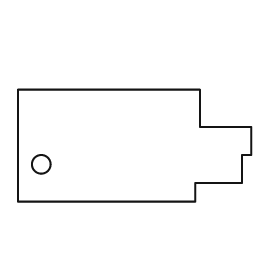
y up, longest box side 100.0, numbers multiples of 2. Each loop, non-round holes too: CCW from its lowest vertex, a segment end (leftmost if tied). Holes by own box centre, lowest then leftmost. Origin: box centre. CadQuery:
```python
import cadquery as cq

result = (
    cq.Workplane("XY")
    .moveTo(-50.0, -24.0)
    .lineTo(26.0, -24.0)
    .lineTo(26.0, -16.0)
    .lineTo(46.0, -16.0)
    .lineTo(46.0, -4.0)
    .lineTo(50.0, -4.0)
    .lineTo(50.0, 8.0)
    .lineTo(28.0, 8.0)
    .lineTo(28.0, 24.0)
    .lineTo(-50.0, 24.0)
    .close()
    .moveTo(-40.0, -8.0)
    .circle(4.0)
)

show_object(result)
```